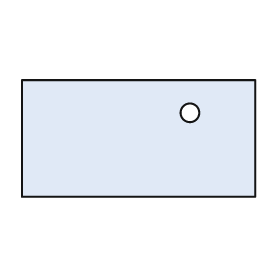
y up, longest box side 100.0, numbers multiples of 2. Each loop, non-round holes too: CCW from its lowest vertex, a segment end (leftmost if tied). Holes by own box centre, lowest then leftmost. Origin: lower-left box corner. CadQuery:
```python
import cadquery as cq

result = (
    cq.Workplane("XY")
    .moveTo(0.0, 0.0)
    .lineTo(100.0, 0.0)
    .lineTo(100.0, 50.0)
    .lineTo(0.0, 50.0)
    .close()
    .moveTo(72.0, 36.0)
    .circle(4.0)
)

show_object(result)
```